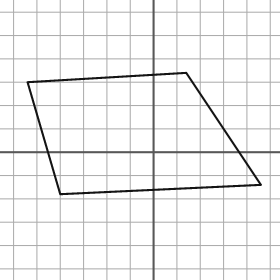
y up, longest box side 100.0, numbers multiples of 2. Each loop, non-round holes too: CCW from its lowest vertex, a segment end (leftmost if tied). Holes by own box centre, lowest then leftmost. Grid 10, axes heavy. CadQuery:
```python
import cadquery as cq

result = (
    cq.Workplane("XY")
    .moveTo(-40.0, -18.0)
    .lineTo(46.0, -14.0)
    .lineTo(14.0, 34.0)
    .lineTo(-54.0, 30.0)
    .close()
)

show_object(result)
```